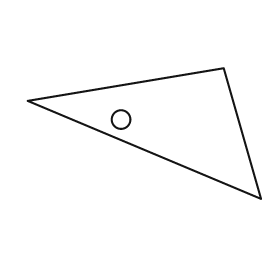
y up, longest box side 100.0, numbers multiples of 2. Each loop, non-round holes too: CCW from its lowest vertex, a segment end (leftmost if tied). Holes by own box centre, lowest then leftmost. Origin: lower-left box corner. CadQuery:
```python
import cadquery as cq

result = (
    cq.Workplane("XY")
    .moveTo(100.0, 0.0)
    .lineTo(84.0, 56.0)
    .lineTo(0.0, 42.0)
    .close()
    .moveTo(40.0, 34.0)
    .circle(4.0)
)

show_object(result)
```